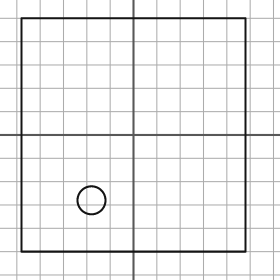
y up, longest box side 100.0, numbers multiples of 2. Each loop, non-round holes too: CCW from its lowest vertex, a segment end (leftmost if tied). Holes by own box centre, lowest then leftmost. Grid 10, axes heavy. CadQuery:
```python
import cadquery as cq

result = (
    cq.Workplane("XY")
    .moveTo(-48.0, -50.0)
    .lineTo(48.0, -50.0)
    .lineTo(48.0, 50.0)
    .lineTo(-48.0, 50.0)
    .close()
    .moveTo(-18.0, -28.0)
    .circle(6.0)
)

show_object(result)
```